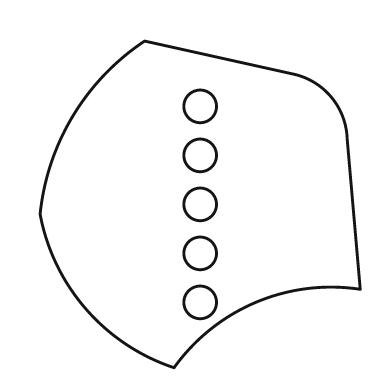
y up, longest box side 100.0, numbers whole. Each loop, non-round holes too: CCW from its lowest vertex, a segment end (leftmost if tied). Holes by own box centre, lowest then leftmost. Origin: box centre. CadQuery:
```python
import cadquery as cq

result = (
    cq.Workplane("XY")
    .moveTo(-8.0, -50.0)
    .threePointArc((17.0, -30.0), (49.0, -26.0))
    .lineTo(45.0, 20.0)
    .threePointArc((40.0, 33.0), (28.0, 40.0))
    .lineTo(-17.0, 50.0)
    .threePointArc((-39.0, 27.0), (-49.0, -3.0))
    .threePointArc((-35.0, -32.0), (-8.0, -50.0))
    .close()
    .moveTo(0.0, -30.0)
    .circle(5.0)
    .moveTo(0.0, -15.0)
    .circle(5.0)
    .moveTo(0.0, 0.0)
    .circle(5.0)
    .moveTo(0.0, 15.0)
    .circle(5.0)
    .moveTo(0.0, 30.0)
    .circle(5.0)
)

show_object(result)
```